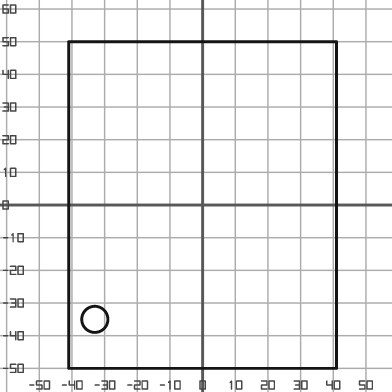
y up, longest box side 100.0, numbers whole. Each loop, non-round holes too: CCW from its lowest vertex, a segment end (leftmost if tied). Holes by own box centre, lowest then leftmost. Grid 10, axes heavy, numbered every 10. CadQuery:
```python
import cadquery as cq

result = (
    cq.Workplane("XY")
    .moveTo(-41.0, -50.0)
    .lineTo(41.0, -50.0)
    .lineTo(41.0, 50.0)
    .lineTo(-41.0, 50.0)
    .close()
    .moveTo(-33.0, -35.0)
    .circle(4.0)
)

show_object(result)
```